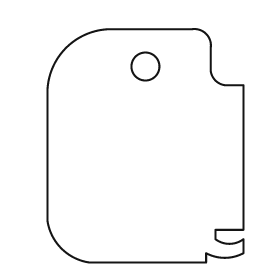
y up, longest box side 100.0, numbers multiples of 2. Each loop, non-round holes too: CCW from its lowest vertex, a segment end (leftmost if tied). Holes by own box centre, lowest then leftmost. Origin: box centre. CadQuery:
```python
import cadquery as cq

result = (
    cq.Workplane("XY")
    .moveTo(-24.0, -50.0)
    .lineTo(26.0, -50.0)
    .lineTo(26.0, -46.0)
    .threePointArc((34.0, -48.0), (42.0, -46.0))
    .lineTo(42.0, -40.0)
    .threePointArc((36.0, -42.0), (30.0, -40.0))
    .lineTo(30.0, -36.0)
    .lineTo(42.0, -36.0)
    .lineTo(42.0, 26.0)
    .lineTo(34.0, 26.0)
    .threePointArc((30.0, 28.0), (28.0, 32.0))
    .lineTo(28.0, 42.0)
    .threePointArc((26.0, 48.0), (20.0, 50.0))
    .lineTo(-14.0, 50.0)
    .threePointArc((-34.0, 42.0), (-42.0, 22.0))
    .lineTo(-42.0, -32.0)
    .threePointArc((-36.0, -44.0), (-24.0, -50.0))
    .close()
    .moveTo(0.0, 34.0)
    .circle(6.0)
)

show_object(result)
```